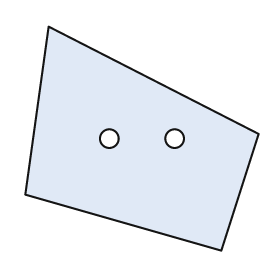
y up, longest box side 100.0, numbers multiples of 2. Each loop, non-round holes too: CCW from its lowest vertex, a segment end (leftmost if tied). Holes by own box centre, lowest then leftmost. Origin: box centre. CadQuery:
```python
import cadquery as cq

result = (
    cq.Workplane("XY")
    .moveTo(34.0, -48.0)
    .lineTo(50.0, 2.0)
    .lineTo(-40.0, 48.0)
    .lineTo(-50.0, -24.0)
    .close()
    .moveTo(-14.0, 0.0)
    .circle(4.0)
    .moveTo(14.0, 0.0)
    .circle(4.0)
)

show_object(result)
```